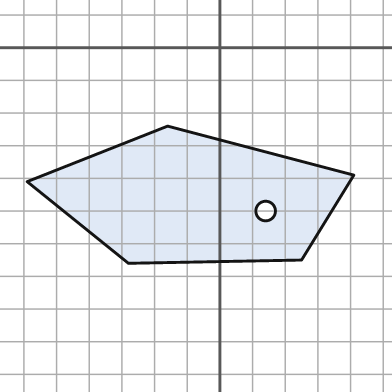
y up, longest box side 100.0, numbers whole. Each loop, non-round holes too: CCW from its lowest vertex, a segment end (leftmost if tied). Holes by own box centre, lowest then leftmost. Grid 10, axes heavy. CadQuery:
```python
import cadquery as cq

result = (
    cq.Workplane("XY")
    .moveTo(-28.0, -66.0)
    .lineTo(25.0, -65.0)
    .lineTo(41.0, -39.0)
    .lineTo(-16.0, -24.0)
    .lineTo(-59.0, -41.0)
    .close()
    .moveTo(14.0, -50.0)
    .circle(3.0)
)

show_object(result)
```